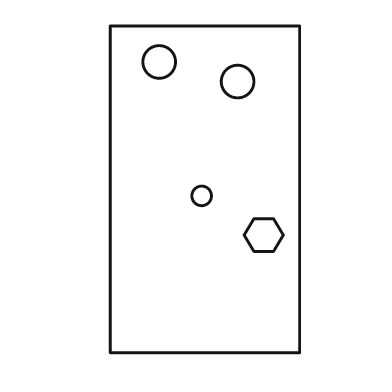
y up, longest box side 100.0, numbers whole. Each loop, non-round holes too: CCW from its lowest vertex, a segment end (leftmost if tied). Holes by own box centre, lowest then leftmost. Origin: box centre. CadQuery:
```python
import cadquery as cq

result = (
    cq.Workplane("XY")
    .moveTo(-29.0, -50.0)
    .lineTo(29.0, -50.0)
    .lineTo(29.0, 50.0)
    .lineTo(-29.0, 50.0)
    .close()
    .moveTo(15.0, -19.0)
    .lineTo(21.0, -19.0)
    .lineTo(24.0, -14.0)
    .lineTo(21.0, -9.0)
    .lineTo(15.0, -9.0)
    .lineTo(12.0, -14.0)
    .close()
    .moveTo(-1.0, -2.0)
    .circle(3.0)
    .moveTo(10.0, 33.0)
    .circle(5.0)
    .moveTo(-14.0, 39.0)
    .circle(5.0)
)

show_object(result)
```